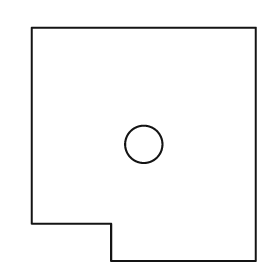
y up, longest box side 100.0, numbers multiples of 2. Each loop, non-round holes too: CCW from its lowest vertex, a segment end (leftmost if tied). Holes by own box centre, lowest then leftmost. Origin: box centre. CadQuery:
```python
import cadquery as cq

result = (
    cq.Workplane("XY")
    .moveTo(-14.0, -50.0)
    .lineTo(48.0, -50.0)
    .lineTo(48.0, 50.0)
    .lineTo(-48.0, 50.0)
    .lineTo(-48.0, -34.0)
    .lineTo(-14.0, -34.0)
    .close()
    .moveTo(0.0, 0.0)
    .circle(8.0)
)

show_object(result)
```